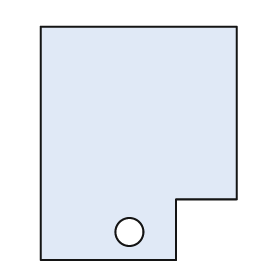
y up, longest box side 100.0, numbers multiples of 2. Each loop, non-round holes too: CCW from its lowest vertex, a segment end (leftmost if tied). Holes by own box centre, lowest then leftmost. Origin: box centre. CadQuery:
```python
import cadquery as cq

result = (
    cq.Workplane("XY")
    .moveTo(-42.0, -50.0)
    .lineTo(16.0, -50.0)
    .lineTo(16.0, -24.0)
    .lineTo(42.0, -24.0)
    .lineTo(42.0, 50.0)
    .lineTo(-42.0, 50.0)
    .close()
    .moveTo(-4.0, -38.0)
    .circle(6.0)
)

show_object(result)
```